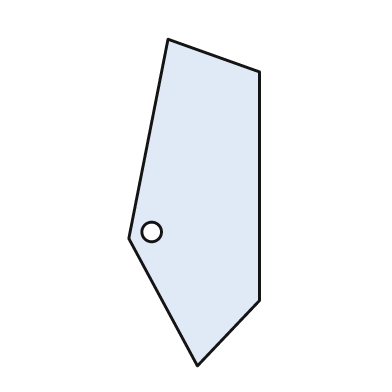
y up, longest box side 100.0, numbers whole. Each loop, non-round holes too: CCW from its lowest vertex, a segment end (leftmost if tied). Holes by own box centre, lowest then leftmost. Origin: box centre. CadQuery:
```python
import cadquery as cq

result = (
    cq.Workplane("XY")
    .moveTo(1.0, -50.0)
    .lineTo(20.0, -30.0)
    .lineTo(20.0, 40.0)
    .lineTo(-8.0, 50.0)
    .lineTo(-20.0, -11.0)
    .close()
    .moveTo(-13.0, -9.0)
    .circle(3.0)
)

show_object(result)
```